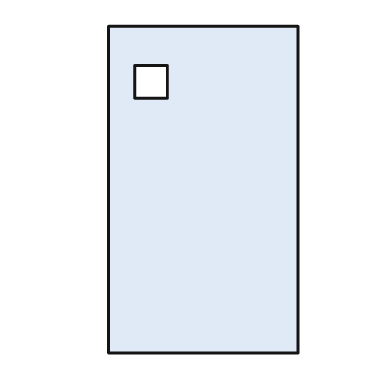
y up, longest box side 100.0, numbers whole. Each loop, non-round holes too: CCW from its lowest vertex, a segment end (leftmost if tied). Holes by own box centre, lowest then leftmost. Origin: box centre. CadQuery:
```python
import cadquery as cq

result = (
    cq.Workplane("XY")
    .moveTo(-29.0, -50.0)
    .lineTo(29.0, -50.0)
    .lineTo(29.0, 50.0)
    .lineTo(-29.0, 50.0)
    .close()
    .moveTo(-21.0, 28.0)
    .lineTo(-11.0, 28.0)
    .lineTo(-11.0, 38.0)
    .lineTo(-21.0, 38.0)
    .close()
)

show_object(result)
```